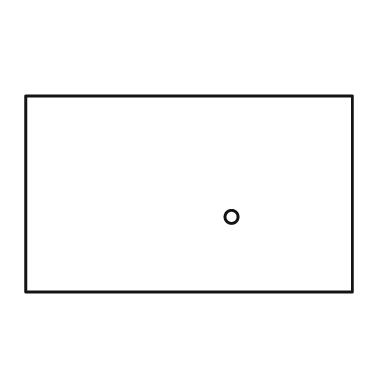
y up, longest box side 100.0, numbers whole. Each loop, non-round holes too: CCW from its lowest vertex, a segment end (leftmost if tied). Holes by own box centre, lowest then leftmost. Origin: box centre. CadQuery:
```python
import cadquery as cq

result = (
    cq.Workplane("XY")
    .moveTo(-50.0, -30.0)
    .lineTo(50.0, -30.0)
    .lineTo(50.0, 30.0)
    .lineTo(-50.0, 30.0)
    .close()
    .moveTo(13.0, -7.0)
    .circle(2.0)
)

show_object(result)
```